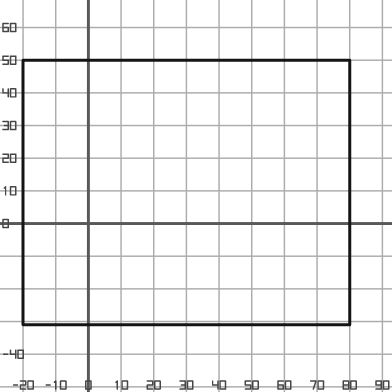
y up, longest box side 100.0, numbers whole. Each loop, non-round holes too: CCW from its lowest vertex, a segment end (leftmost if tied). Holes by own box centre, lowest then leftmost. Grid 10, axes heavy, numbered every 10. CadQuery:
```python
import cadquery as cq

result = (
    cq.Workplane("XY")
    .moveTo(-20.0, -31.0)
    .lineTo(80.0, -31.0)
    .lineTo(80.0, 50.0)
    .lineTo(-20.0, 50.0)
    .close()
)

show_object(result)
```